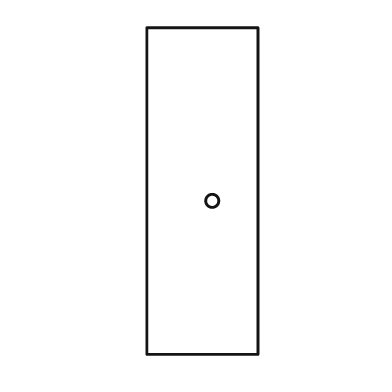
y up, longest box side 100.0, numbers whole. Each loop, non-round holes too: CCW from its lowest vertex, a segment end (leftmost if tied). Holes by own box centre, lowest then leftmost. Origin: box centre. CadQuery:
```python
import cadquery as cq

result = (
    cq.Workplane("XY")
    .moveTo(-17.0, -50.0)
    .lineTo(17.0, -50.0)
    .lineTo(17.0, 50.0)
    .lineTo(-17.0, 50.0)
    .close()
    .moveTo(3.0, -3.0)
    .circle(2.0)
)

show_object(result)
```